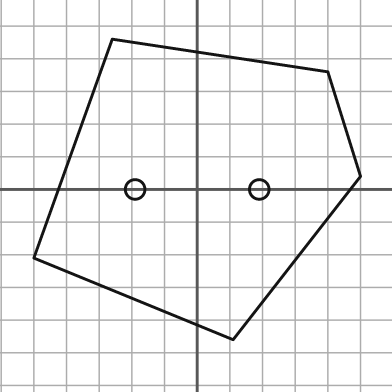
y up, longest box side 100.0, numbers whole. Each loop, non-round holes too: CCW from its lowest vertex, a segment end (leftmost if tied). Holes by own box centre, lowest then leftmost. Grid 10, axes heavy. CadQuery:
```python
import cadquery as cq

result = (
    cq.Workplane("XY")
    .moveTo(11.0, -46.0)
    .lineTo(50.0, 4.0)
    .lineTo(40.0, 36.0)
    .lineTo(-26.0, 46.0)
    .lineTo(-50.0, -21.0)
    .close()
    .moveTo(-19.0, 0.0)
    .circle(3.0)
    .moveTo(19.0, 0.0)
    .circle(3.0)
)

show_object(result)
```